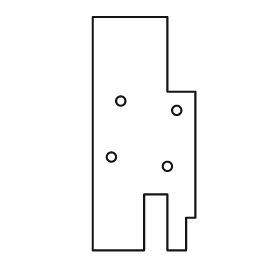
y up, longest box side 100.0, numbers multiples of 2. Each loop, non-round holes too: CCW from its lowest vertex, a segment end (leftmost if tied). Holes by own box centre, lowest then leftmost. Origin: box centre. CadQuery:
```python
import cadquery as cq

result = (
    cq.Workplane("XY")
    .moveTo(-22.0, -50.0)
    .lineTo(0.0, -50.0)
    .lineTo(0.0, -26.0)
    .lineTo(10.0, -26.0)
    .lineTo(10.0, -50.0)
    .lineTo(18.0, -50.0)
    .lineTo(18.0, -36.0)
    .lineTo(22.0, -36.0)
    .lineTo(22.0, 18.0)
    .lineTo(10.0, 18.0)
    .lineTo(10.0, 50.0)
    .lineTo(-22.0, 50.0)
    .close()
    .moveTo(10.0, -14.0)
    .circle(2.0)
    .moveTo(-14.0, -10.0)
    .circle(2.0)
    .moveTo(14.0, 10.0)
    .circle(2.0)
    .moveTo(-10.0, 14.0)
    .circle(2.0)
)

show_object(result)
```